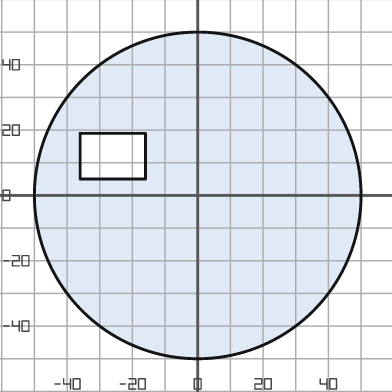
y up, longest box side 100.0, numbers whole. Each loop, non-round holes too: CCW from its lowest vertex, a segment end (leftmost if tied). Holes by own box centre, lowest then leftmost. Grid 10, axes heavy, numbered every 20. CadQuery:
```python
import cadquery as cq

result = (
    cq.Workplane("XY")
    .moveTo(0.0, 0.0)
    .circle(50.0)
    .moveTo(-36.0, 5.0)
    .lineTo(-16.0, 5.0)
    .lineTo(-16.0, 19.0)
    .lineTo(-36.0, 19.0)
    .close()
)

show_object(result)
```